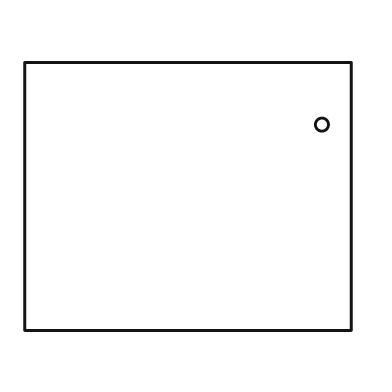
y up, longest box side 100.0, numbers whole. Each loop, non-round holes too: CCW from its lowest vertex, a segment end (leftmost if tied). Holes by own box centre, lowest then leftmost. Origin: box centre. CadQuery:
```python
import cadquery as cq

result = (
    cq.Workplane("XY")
    .moveTo(-50.0, -41.0)
    .lineTo(50.0, -41.0)
    .lineTo(50.0, 41.0)
    .lineTo(-50.0, 41.0)
    .close()
    .moveTo(41.0, 22.0)
    .circle(2.0)
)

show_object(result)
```